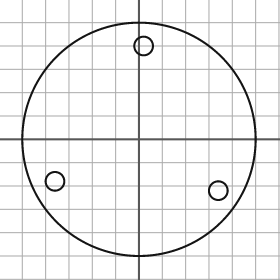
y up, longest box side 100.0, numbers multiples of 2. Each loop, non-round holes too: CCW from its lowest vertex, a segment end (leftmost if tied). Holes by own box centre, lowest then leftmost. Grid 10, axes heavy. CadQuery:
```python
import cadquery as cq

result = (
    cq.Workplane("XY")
    .moveTo(0.0, 0.0)
    .circle(50.0)
    .moveTo(34.0, -22.0)
    .circle(4.0)
    .moveTo(-36.0, -18.0)
    .circle(4.0)
    .moveTo(2.0, 40.0)
    .circle(4.0)
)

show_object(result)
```